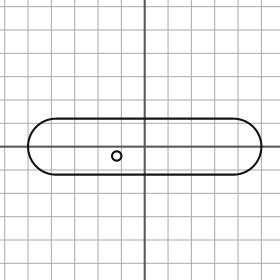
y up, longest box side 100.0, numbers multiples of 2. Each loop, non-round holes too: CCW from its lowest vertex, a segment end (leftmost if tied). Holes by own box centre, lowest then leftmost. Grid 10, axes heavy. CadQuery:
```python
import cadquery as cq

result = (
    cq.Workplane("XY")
    .moveTo(-38.0, -12.0)
    .lineTo(38.0, -12.0)
    .threePointArc((50.0, 0.0), (38.0, 12.0))
    .lineTo(-38.0, 12.0)
    .threePointArc((-50.0, 0.0), (-38.0, -12.0))
    .close()
    .moveTo(-12.0, -4.0)
    .circle(2.0)
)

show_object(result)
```